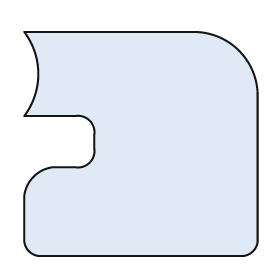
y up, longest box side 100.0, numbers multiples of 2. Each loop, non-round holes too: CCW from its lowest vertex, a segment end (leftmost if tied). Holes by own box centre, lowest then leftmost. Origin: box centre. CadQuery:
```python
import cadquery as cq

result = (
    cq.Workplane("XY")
    .moveTo(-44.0, -48.0)
    .lineTo(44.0, -48.0)
    .threePointArc((48.0, -46.0), (50.0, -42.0))
    .lineTo(50.0, 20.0)
    .threePointArc((42.0, 40.0), (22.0, 48.0))
    .lineTo(-50.0, 48.0)
    .threePointArc((-44.0, 30.0), (-50.0, 12.0))
    .lineTo(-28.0, 12.0)
    .threePointArc((-22.0, 10.0), (-20.0, 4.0))
    .lineTo(-20.0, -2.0)
    .threePointArc((-22.0, -8.0), (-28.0, -10.0))
    .lineTo(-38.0, -10.0)
    .threePointArc((-46.0, -14.0), (-50.0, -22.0))
    .lineTo(-50.0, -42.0)
    .threePointArc((-48.0, -46.0), (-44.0, -48.0))
    .close()
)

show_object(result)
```